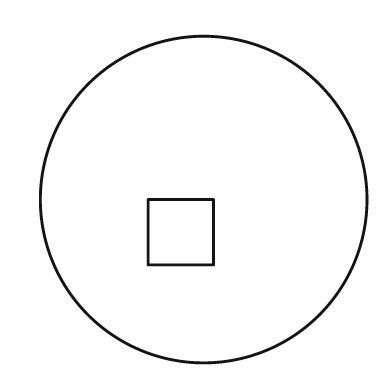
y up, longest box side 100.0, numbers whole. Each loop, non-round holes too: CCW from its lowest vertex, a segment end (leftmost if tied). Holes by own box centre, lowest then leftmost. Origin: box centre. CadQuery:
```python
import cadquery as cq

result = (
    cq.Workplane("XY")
    .moveTo(0.0, 0.0)
    .circle(50.0)
    .moveTo(-17.0, -20.0)
    .lineTo(3.0, -20.0)
    .lineTo(3.0, 0.0)
    .lineTo(-17.0, 0.0)
    .close()
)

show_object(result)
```